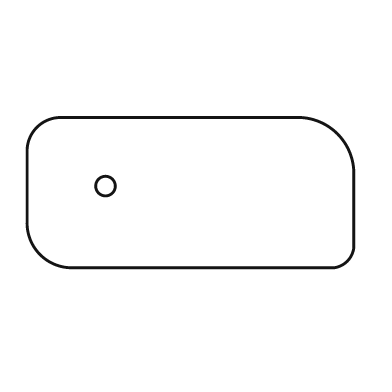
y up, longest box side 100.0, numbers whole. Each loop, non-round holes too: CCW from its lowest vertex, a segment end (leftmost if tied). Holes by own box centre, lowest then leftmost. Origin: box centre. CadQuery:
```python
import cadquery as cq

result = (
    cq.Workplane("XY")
    .moveTo(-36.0, -23.0)
    .lineTo(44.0, -23.0)
    .threePointArc((48.0, -21.0), (50.0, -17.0))
    .lineTo(50.0, 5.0)
    .threePointArc((45.0, 18.0), (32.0, 23.0))
    .lineTo(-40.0, 23.0)
    .threePointArc((-47.0, 20.0), (-50.0, 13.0))
    .lineTo(-50.0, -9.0)
    .threePointArc((-46.0, -19.0), (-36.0, -23.0))
    .close()
    .moveTo(-26.0, 2.0)
    .circle(3.0)
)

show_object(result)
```